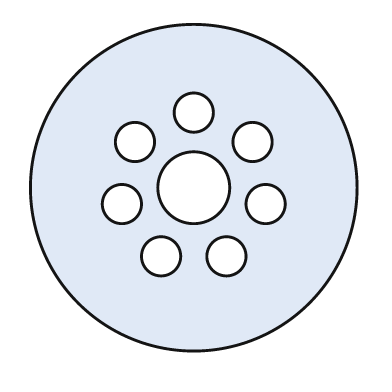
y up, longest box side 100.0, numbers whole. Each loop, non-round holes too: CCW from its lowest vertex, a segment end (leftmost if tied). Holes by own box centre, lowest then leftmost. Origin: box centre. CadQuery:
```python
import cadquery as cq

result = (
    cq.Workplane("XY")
    .moveTo(0.0, 0.0)
    .circle(50.0)
    .moveTo(-10.0, -21.0)
    .circle(6.0)
    .moveTo(10.0, -21.0)
    .circle(6.0)
    .moveTo(-22.0, -5.0)
    .circle(6.0)
    .moveTo(22.0, -5.0)
    .circle(6.0)
    .moveTo(0.0, 0.0)
    .circle(11.0)
    .moveTo(-18.0, 14.0)
    .circle(6.0)
    .moveTo(18.0, 14.0)
    .circle(6.0)
    .moveTo(0.0, 23.0)
    .circle(6.0)
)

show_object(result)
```